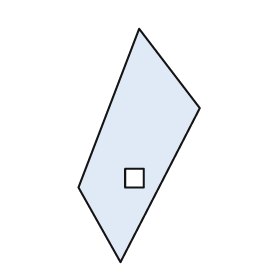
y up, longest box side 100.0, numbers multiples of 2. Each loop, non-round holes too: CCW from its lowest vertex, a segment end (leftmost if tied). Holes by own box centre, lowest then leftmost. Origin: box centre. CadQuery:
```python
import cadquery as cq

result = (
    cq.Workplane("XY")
    .moveTo(-8.0, -50.0)
    .lineTo(26.0, 16.0)
    .lineTo(0.0, 50.0)
    .lineTo(-26.0, -18.0)
    .close()
    .moveTo(-6.0, -18.0)
    .lineTo(2.0, -18.0)
    .lineTo(2.0, -10.0)
    .lineTo(-6.0, -10.0)
    .close()
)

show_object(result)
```